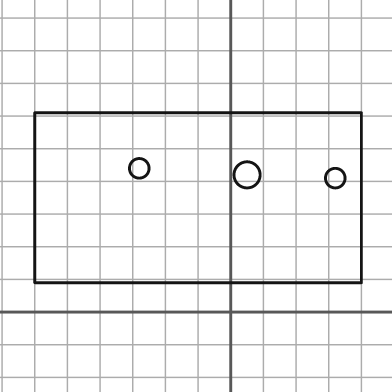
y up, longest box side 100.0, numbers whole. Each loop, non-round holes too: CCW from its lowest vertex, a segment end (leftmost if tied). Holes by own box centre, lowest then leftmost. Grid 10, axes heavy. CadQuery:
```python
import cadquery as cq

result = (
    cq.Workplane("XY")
    .moveTo(-60.0, 9.0)
    .lineTo(40.0, 9.0)
    .lineTo(40.0, 61.0)
    .lineTo(-60.0, 61.0)
    .close()
    .moveTo(32.0, 41.0)
    .circle(3.0)
    .moveTo(5.0, 42.0)
    .circle(4.0)
    .moveTo(-28.0, 44.0)
    .circle(3.0)
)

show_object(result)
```